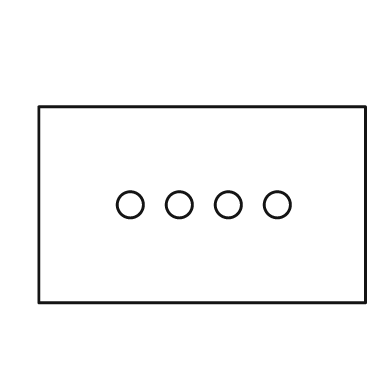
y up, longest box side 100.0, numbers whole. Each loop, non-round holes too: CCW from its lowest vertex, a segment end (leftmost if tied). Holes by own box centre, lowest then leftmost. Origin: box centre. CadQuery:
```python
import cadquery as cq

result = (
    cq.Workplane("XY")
    .moveTo(-50.0, -30.0)
    .lineTo(50.0, -30.0)
    .lineTo(50.0, 30.0)
    .lineTo(-50.0, 30.0)
    .close()
    .moveTo(-22.0, 0.0)
    .circle(4.0)
    .moveTo(-7.0, 0.0)
    .circle(4.0)
    .moveTo(8.0, 0.0)
    .circle(4.0)
    .moveTo(23.0, 0.0)
    .circle(4.0)
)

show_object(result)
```